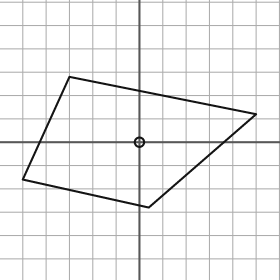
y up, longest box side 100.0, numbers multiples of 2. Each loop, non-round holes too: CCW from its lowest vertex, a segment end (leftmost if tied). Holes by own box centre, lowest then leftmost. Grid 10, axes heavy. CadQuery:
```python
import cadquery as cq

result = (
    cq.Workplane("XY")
    .moveTo(4.0, -28.0)
    .lineTo(50.0, 12.0)
    .lineTo(-30.0, 28.0)
    .lineTo(-50.0, -16.0)
    .close()
    .moveTo(0.0, 0.0)
    .circle(2.0)
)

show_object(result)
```